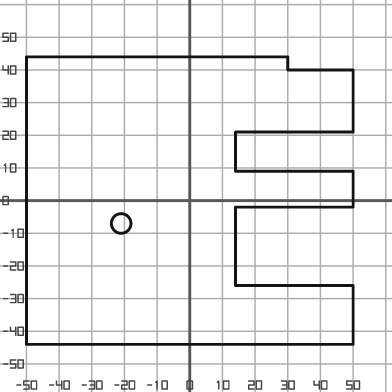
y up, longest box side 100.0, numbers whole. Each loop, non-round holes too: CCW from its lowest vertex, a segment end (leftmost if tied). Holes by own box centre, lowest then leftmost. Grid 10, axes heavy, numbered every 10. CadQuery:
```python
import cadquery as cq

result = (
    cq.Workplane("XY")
    .moveTo(-50.0, -44.0)
    .lineTo(50.0, -44.0)
    .lineTo(50.0, -26.0)
    .lineTo(14.0, -26.0)
    .lineTo(14.0, -2.0)
    .lineTo(50.0, -2.0)
    .lineTo(50.0, 9.0)
    .lineTo(14.0, 9.0)
    .lineTo(14.0, 21.0)
    .lineTo(50.0, 21.0)
    .lineTo(50.0, 40.0)
    .lineTo(30.0, 40.0)
    .lineTo(30.0, 44.0)
    .lineTo(-50.0, 44.0)
    .close()
    .moveTo(-21.0, -7.0)
    .circle(3.0)
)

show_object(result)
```